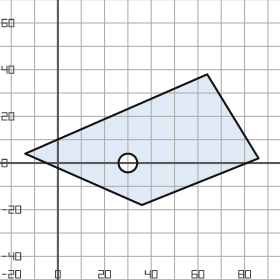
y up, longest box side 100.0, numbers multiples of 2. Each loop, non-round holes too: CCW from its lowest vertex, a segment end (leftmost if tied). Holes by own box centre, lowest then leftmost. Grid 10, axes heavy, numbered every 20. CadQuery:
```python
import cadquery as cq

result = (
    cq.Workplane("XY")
    .moveTo(36.0, -18.0)
    .lineTo(86.0, 2.0)
    .lineTo(64.0, 38.0)
    .lineTo(-14.0, 4.0)
    .close()
    .moveTo(30.0, 0.0)
    .circle(4.0)
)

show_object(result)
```